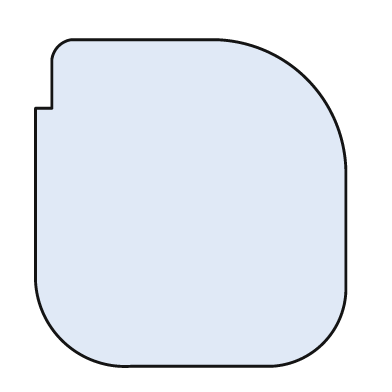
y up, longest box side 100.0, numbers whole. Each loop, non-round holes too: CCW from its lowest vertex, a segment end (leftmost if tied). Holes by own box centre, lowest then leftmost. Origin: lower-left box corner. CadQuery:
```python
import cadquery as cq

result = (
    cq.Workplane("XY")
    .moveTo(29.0, 0.0)
    .lineTo(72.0, 0.0)
    .threePointArc((88.0, 7.0), (95.0, 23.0))
    .lineTo(95.0, 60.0)
    .threePointArc((83.0, 88.0), (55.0, 100.0))
    .lineTo(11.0, 100.0)
    .threePointArc((7.0, 98.0), (5.0, 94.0))
    .lineTo(5.0, 79.0)
    .lineTo(0.0, 79.0)
    .lineTo(0.0, 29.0)
    .threePointArc((8.0, 8.0), (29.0, 0.0))
    .close()
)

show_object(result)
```